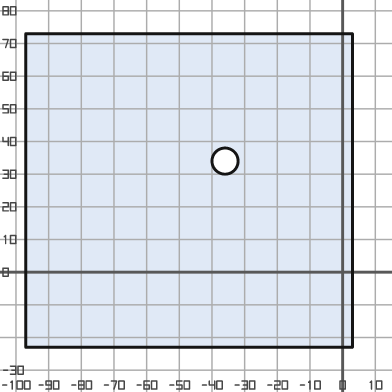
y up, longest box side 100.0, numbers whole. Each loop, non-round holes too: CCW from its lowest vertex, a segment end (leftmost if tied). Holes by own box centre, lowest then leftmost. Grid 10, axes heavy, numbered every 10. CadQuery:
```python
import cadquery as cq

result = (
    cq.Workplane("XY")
    .moveTo(-97.0, -23.0)
    .lineTo(3.0, -23.0)
    .lineTo(3.0, 73.0)
    .lineTo(-97.0, 73.0)
    .close()
    .moveTo(-36.0, 34.0)
    .circle(4.0)
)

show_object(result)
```